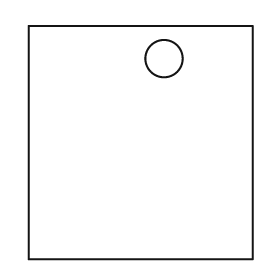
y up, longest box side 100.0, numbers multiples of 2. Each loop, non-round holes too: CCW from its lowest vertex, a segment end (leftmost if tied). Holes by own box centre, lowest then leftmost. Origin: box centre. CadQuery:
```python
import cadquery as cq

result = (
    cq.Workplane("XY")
    .moveTo(-48.0, -50.0)
    .lineTo(48.0, -50.0)
    .lineTo(48.0, 50.0)
    .lineTo(-48.0, 50.0)
    .close()
    .moveTo(10.0, 36.0)
    .circle(8.0)
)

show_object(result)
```